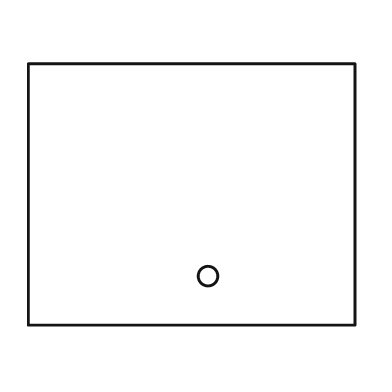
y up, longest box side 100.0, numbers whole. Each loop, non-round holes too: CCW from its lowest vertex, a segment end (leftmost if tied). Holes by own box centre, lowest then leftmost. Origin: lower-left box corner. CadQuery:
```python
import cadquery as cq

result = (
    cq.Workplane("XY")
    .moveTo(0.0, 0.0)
    .lineTo(100.0, 0.0)
    .lineTo(100.0, 80.0)
    .lineTo(0.0, 80.0)
    .close()
    .moveTo(55.0, 15.0)
    .circle(3.0)
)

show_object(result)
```